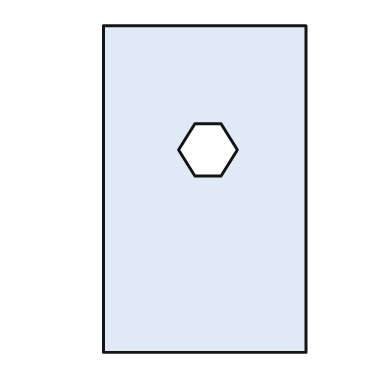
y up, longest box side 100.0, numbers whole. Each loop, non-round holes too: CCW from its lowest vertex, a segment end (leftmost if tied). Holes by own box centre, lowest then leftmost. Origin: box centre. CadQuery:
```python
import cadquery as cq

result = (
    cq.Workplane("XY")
    .moveTo(-31.0, -50.0)
    .lineTo(31.0, -50.0)
    .lineTo(31.0, 50.0)
    .lineTo(-31.0, 50.0)
    .close()
    .moveTo(-3.0, 4.0)
    .lineTo(5.0, 4.0)
    .lineTo(10.0, 12.0)
    .lineTo(5.0, 20.0)
    .lineTo(-3.0, 20.0)
    .lineTo(-8.0, 12.0)
    .close()
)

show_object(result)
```